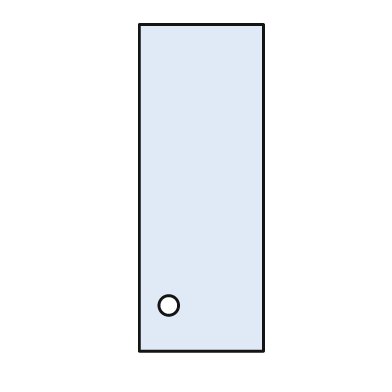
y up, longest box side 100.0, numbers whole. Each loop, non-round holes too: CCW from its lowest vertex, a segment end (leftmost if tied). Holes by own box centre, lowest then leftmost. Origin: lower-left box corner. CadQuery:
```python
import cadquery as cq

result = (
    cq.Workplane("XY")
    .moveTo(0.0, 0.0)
    .lineTo(38.0, 0.0)
    .lineTo(38.0, 100.0)
    .lineTo(0.0, 100.0)
    .close()
    .moveTo(9.0, 14.0)
    .circle(3.0)
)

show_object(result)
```